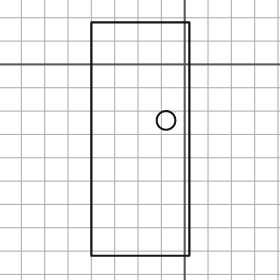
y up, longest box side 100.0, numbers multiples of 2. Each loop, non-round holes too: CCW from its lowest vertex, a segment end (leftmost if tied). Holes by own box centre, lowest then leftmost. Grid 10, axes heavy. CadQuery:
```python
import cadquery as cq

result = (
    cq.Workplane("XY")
    .moveTo(-40.0, -82.0)
    .lineTo(2.0, -82.0)
    .lineTo(2.0, 18.0)
    .lineTo(-40.0, 18.0)
    .close()
    .moveTo(-8.0, -24.0)
    .circle(4.0)
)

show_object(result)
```